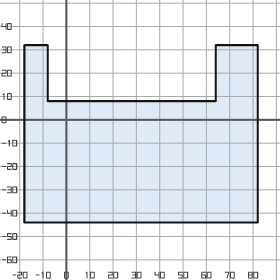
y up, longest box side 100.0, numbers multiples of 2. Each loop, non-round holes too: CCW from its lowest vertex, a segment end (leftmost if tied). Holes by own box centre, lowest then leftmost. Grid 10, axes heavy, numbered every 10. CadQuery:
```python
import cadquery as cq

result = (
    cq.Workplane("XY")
    .moveTo(-18.0, -44.0)
    .lineTo(82.0, -44.0)
    .lineTo(82.0, 32.0)
    .lineTo(64.0, 32.0)
    .lineTo(64.0, 8.0)
    .lineTo(-8.0, 8.0)
    .lineTo(-8.0, 32.0)
    .lineTo(-18.0, 32.0)
    .close()
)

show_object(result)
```